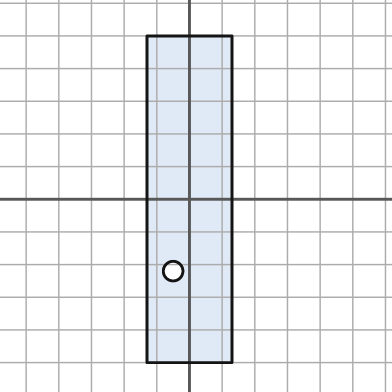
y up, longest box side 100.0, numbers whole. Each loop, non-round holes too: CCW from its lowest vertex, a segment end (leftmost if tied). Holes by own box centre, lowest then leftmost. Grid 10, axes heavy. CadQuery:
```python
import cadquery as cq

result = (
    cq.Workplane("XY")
    .moveTo(-13.0, -50.0)
    .lineTo(13.0, -50.0)
    .lineTo(13.0, 50.0)
    .lineTo(-13.0, 50.0)
    .close()
    .moveTo(-5.0, -22.0)
    .circle(3.0)
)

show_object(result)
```